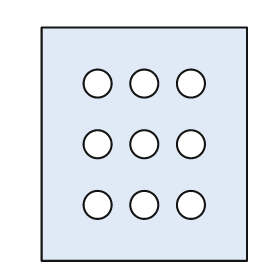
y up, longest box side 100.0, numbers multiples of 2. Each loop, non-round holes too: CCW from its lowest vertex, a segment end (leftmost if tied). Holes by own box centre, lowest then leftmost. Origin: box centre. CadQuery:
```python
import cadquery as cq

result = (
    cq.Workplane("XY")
    .moveTo(-44.0, -50.0)
    .lineTo(44.0, -50.0)
    .lineTo(44.0, 50.0)
    .lineTo(-44.0, 50.0)
    .close()
    .moveTo(-20.0, -26.0)
    .circle(6.0)
    .moveTo(0.0, -26.0)
    .circle(6.0)
    .moveTo(20.0, -26.0)
    .circle(6.0)
    .moveTo(-20.0, 0.0)
    .circle(6.0)
    .moveTo(0.0, 0.0)
    .circle(6.0)
    .moveTo(20.0, 0.0)
    .circle(6.0)
    .moveTo(-20.0, 26.0)
    .circle(6.0)
    .moveTo(0.0, 26.0)
    .circle(6.0)
    .moveTo(20.0, 26.0)
    .circle(6.0)
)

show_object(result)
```